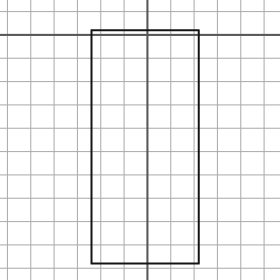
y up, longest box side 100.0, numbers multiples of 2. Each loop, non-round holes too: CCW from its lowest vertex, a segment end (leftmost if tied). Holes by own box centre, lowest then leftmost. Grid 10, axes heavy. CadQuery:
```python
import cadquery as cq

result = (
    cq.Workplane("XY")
    .moveTo(-24.0, -98.0)
    .lineTo(22.0, -98.0)
    .lineTo(22.0, 2.0)
    .lineTo(-24.0, 2.0)
    .close()
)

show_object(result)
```